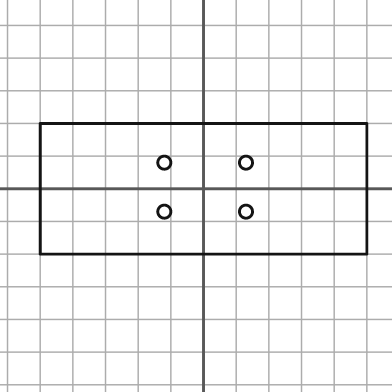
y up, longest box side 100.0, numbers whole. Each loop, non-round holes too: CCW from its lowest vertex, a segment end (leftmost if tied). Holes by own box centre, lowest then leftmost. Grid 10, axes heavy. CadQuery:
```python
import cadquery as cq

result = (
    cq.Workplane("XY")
    .moveTo(-50.0, -20.0)
    .lineTo(50.0, -20.0)
    .lineTo(50.0, 20.0)
    .lineTo(-50.0, 20.0)
    .close()
    .moveTo(-12.0, -7.0)
    .circle(2.0)
    .moveTo(13.0, -7.0)
    .circle(2.0)
    .moveTo(-12.0, 8.0)
    .circle(2.0)
    .moveTo(13.0, 8.0)
    .circle(2.0)
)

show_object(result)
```